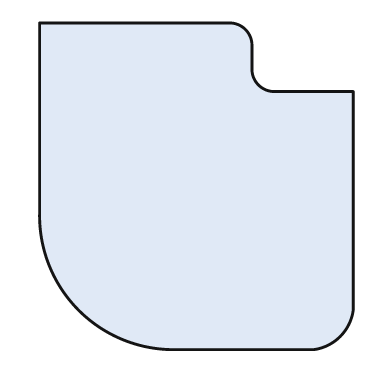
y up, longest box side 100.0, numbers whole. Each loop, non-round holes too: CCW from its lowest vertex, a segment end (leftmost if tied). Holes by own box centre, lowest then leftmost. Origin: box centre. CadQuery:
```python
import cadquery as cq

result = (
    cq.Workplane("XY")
    .moveTo(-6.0, -50.0)
    .lineTo(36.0, -50.0)
    .threePointArc((44.0, -46.0), (48.0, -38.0))
    .lineTo(48.0, 29.0)
    .lineTo(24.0, 29.0)
    .threePointArc((19.0, 31.0), (17.0, 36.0))
    .lineTo(17.0, 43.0)
    .threePointArc((15.0, 48.0), (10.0, 50.0))
    .lineTo(-48.0, 50.0)
    .lineTo(-48.0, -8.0)
    .threePointArc((-36.0, -38.0), (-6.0, -50.0))
    .close()
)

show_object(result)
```